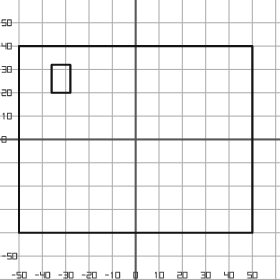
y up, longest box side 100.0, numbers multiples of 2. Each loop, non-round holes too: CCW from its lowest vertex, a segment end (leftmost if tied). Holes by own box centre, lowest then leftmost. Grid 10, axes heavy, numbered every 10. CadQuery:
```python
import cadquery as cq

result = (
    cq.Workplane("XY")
    .moveTo(-50.0, -40.0)
    .lineTo(50.0, -40.0)
    .lineTo(50.0, 40.0)
    .lineTo(-50.0, 40.0)
    .close()
    .moveTo(-36.0, 20.0)
    .lineTo(-28.0, 20.0)
    .lineTo(-28.0, 32.0)
    .lineTo(-36.0, 32.0)
    .close()
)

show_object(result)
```